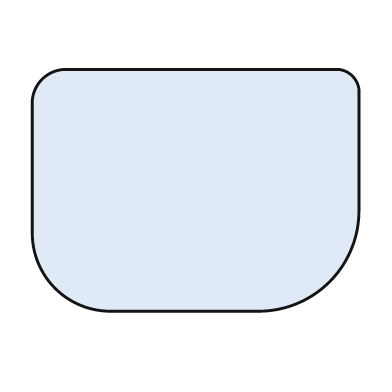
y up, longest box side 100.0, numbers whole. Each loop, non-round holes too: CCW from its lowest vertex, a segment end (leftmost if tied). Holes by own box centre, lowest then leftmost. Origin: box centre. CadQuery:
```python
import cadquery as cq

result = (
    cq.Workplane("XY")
    .moveTo(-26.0, -37.0)
    .lineTo(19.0, -37.0)
    .threePointArc((41.0, -28.0), (50.0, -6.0))
    .lineTo(50.0, 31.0)
    .threePointArc((48.0, 35.0), (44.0, 37.0))
    .lineTo(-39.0, 37.0)
    .threePointArc((-47.0, 34.0), (-50.0, 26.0))
    .lineTo(-50.0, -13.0)
    .threePointArc((-43.0, -30.0), (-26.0, -37.0))
    .close()
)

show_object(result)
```